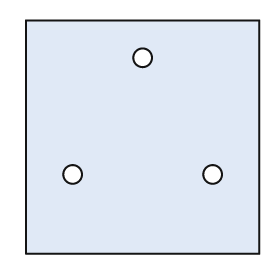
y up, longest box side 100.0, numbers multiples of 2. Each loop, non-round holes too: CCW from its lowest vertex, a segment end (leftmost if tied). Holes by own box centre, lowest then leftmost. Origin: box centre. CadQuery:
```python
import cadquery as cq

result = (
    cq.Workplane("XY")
    .moveTo(-50.0, -50.0)
    .lineTo(50.0, -50.0)
    .lineTo(50.0, 50.0)
    .lineTo(-50.0, 50.0)
    .close()
    .moveTo(-30.0, -16.0)
    .circle(4.0)
    .moveTo(30.0, -16.0)
    .circle(4.0)
    .moveTo(0.0, 34.0)
    .circle(4.0)
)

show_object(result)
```